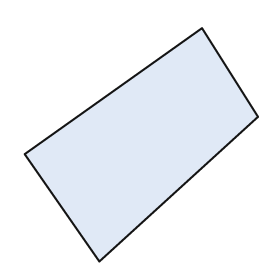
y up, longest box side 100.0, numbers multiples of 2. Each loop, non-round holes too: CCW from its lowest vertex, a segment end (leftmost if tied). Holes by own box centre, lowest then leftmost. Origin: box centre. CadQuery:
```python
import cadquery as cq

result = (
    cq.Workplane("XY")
    .moveTo(-18.0, -50.0)
    .lineTo(50.0, 12.0)
    .lineTo(26.0, 50.0)
    .lineTo(-50.0, -4.0)
    .close()
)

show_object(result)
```